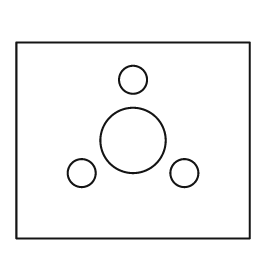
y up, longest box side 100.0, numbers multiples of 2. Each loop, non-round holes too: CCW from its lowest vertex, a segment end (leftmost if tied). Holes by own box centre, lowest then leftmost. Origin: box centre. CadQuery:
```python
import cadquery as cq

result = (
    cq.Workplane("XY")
    .moveTo(-50.0, -42.0)
    .lineTo(50.0, -42.0)
    .lineTo(50.0, 42.0)
    .lineTo(-50.0, 42.0)
    .close()
    .moveTo(-22.0, -14.0)
    .circle(6.0)
    .moveTo(22.0, -14.0)
    .circle(6.0)
    .moveTo(0.0, 0.0)
    .circle(14.0)
    .moveTo(0.0, 26.0)
    .circle(6.0)
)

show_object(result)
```